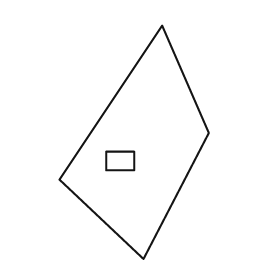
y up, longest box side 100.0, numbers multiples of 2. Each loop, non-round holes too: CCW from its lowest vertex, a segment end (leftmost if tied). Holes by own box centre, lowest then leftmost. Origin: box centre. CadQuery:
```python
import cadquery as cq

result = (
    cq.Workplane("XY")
    .moveTo(4.0, -50.0)
    .lineTo(32.0, 4.0)
    .lineTo(12.0, 50.0)
    .lineTo(-32.0, -16.0)
    .close()
    .moveTo(-12.0, -12.0)
    .lineTo(0.0, -12.0)
    .lineTo(0.0, -4.0)
    .lineTo(-12.0, -4.0)
    .close()
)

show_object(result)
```